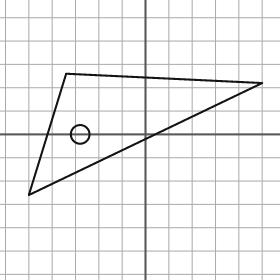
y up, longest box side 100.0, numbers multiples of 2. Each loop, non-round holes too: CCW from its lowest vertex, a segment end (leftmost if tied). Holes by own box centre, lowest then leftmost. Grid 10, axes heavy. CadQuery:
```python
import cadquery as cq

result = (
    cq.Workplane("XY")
    .moveTo(-50.0, -26.0)
    .lineTo(50.0, 22.0)
    .lineTo(-34.0, 26.0)
    .close()
    .moveTo(-28.0, 0.0)
    .circle(4.0)
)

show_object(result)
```